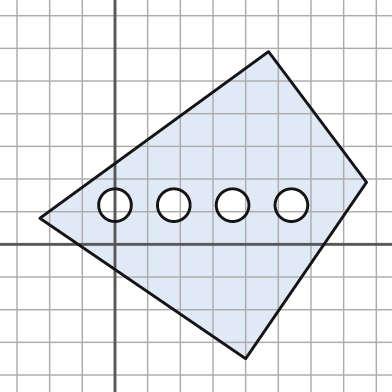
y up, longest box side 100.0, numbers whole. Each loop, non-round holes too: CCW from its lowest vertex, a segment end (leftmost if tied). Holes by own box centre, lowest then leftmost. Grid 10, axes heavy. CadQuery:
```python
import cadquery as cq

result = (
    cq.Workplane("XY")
    .moveTo(40.0, -35.0)
    .lineTo(77.0, 19.0)
    .lineTo(47.0, 59.0)
    .lineTo(-23.0, 8.0)
    .close()
    .moveTo(0.0, 12.0)
    .circle(5.0)
    .moveTo(18.0, 12.0)
    .circle(5.0)
    .moveTo(36.0, 12.0)
    .circle(5.0)
    .moveTo(54.0, 12.0)
    .circle(5.0)
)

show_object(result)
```